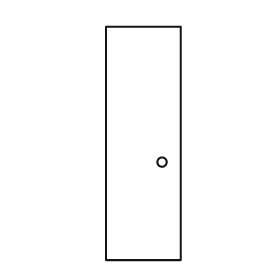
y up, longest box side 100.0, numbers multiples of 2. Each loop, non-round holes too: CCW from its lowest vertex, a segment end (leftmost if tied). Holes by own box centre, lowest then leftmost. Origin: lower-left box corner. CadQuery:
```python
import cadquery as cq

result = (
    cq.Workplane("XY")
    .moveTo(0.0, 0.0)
    .lineTo(32.0, 0.0)
    .lineTo(32.0, 100.0)
    .lineTo(0.0, 100.0)
    .close()
    .moveTo(24.0, 42.0)
    .circle(2.0)
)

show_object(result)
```